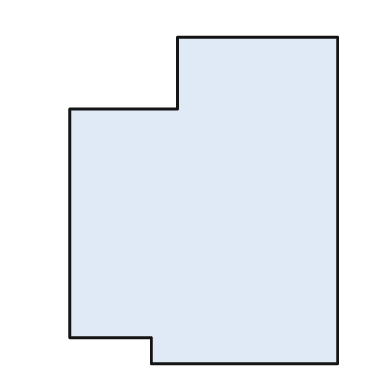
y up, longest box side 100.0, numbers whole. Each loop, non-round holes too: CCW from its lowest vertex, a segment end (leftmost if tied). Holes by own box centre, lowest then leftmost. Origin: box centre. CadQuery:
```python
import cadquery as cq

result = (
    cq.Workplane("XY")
    .moveTo(-16.0, -50.0)
    .lineTo(41.0, -50.0)
    .lineTo(41.0, 50.0)
    .lineTo(-8.0, 50.0)
    .lineTo(-8.0, 28.0)
    .lineTo(-41.0, 28.0)
    .lineTo(-41.0, -42.0)
    .lineTo(-16.0, -42.0)
    .close()
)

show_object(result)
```